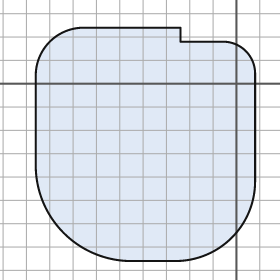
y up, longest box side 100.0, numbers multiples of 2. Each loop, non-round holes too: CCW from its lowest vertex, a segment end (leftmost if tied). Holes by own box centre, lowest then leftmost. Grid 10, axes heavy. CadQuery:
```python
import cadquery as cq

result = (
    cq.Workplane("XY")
    .moveTo(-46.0, -76.0)
    .lineTo(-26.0, -76.0)
    .threePointArc((-2.0, -66.0), (8.0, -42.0))
    .lineTo(8.0, 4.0)
    .threePointArc((4.0, 14.0), (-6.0, 18.0))
    .lineTo(-24.0, 18.0)
    .lineTo(-24.0, 24.0)
    .lineTo(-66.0, 24.0)
    .threePointArc((-80.0, 18.0), (-86.0, 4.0))
    .lineTo(-86.0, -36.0)
    .threePointArc((-74.0, -64.0), (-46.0, -76.0))
    .close()
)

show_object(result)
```